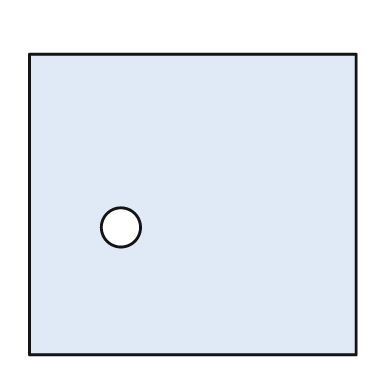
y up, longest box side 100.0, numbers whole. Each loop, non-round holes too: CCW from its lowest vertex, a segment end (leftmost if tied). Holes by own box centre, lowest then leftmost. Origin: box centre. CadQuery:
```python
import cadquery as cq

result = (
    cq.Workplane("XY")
    .moveTo(-50.0, -46.0)
    .lineTo(50.0, -46.0)
    .lineTo(50.0, 46.0)
    .lineTo(-50.0, 46.0)
    .close()
    .moveTo(-22.0, -7.0)
    .circle(6.0)
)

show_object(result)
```